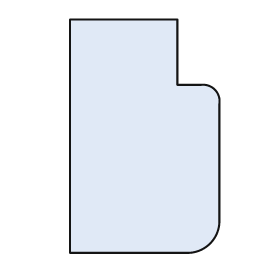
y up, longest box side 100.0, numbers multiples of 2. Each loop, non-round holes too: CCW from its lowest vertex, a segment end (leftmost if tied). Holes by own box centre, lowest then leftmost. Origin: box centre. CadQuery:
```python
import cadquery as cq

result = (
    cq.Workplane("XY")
    .moveTo(-32.0, -50.0)
    .lineTo(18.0, -50.0)
    .threePointArc((28.0, -46.0), (32.0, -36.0))
    .lineTo(32.0, 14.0)
    .threePointArc((30.0, 20.0), (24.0, 22.0))
    .lineTo(14.0, 22.0)
    .lineTo(14.0, 50.0)
    .lineTo(-32.0, 50.0)
    .close()
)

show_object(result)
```